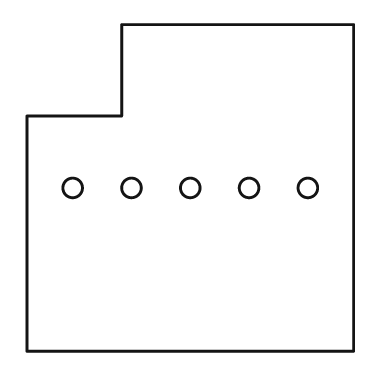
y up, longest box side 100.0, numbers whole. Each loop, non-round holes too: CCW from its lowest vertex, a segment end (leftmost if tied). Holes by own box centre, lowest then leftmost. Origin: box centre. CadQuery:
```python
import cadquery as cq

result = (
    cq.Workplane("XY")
    .moveTo(-50.0, -50.0)
    .lineTo(50.0, -50.0)
    .lineTo(50.0, 50.0)
    .lineTo(-21.0, 50.0)
    .lineTo(-21.0, 22.0)
    .lineTo(-50.0, 22.0)
    .close()
    .moveTo(-36.0, 0.0)
    .circle(3.0)
    .moveTo(-18.0, 0.0)
    .circle(3.0)
    .moveTo(0.0, 0.0)
    .circle(3.0)
    .moveTo(18.0, 0.0)
    .circle(3.0)
    .moveTo(36.0, 0.0)
    .circle(3.0)
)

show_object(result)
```